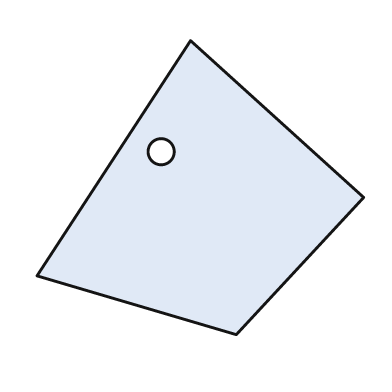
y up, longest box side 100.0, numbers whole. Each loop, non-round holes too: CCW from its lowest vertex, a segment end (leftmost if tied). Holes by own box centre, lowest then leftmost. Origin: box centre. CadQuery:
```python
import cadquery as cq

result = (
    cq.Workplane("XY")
    .moveTo(11.0, -45.0)
    .lineTo(50.0, -3.0)
    .lineTo(-3.0, 45.0)
    .lineTo(-50.0, -27.0)
    .close()
    .moveTo(-12.0, 11.0)
    .circle(4.0)
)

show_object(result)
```